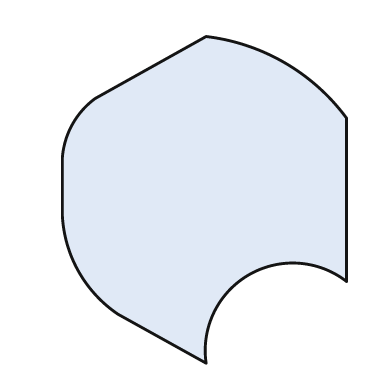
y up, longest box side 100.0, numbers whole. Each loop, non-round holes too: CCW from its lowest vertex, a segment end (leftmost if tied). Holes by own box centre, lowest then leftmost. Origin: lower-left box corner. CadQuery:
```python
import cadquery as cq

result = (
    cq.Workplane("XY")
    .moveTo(44.0, 0.0)
    .threePointArc((57.0, 27.0), (87.0, 25.0))
    .lineTo(87.0, 75.0)
    .threePointArc((68.0, 92.0), (44.0, 100.0))
    .lineTo(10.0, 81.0)
    .threePointArc((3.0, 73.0), (0.0, 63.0))
    .lineTo(0.0, 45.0)
    .threePointArc((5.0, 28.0), (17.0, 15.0))
    .close()
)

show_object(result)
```